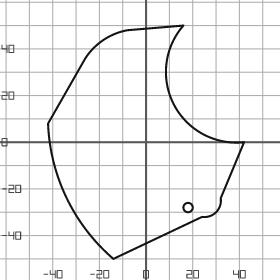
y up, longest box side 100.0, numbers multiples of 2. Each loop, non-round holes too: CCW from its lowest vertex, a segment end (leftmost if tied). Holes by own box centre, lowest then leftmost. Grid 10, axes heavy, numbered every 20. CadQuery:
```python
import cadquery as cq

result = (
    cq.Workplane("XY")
    .moveTo(-14.0, -50.0)
    .lineTo(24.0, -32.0)
    .threePointArc((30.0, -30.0), (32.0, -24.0))
    .lineTo(42.0, 0.0)
    .threePointArc((12.0, 16.0), (16.0, 50.0))
    .lineTo(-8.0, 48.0)
    .threePointArc((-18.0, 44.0), (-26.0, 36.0))
    .lineTo(-42.0, 8.0)
    .threePointArc((-34.0, -24.0), (-14.0, -50.0))
    .close()
    .moveTo(18.0, -28.0)
    .circle(2.0)
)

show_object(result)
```